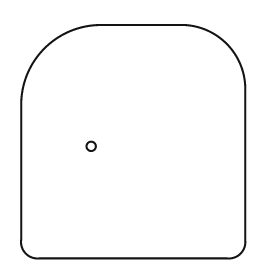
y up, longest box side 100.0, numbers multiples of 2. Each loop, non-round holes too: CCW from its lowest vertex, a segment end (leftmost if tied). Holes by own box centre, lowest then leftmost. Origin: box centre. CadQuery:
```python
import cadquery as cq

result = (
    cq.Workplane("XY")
    .moveTo(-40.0, -50.0)
    .lineTo(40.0, -50.0)
    .threePointArc((46.0, -48.0), (48.0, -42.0))
    .lineTo(48.0, 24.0)
    .threePointArc((40.0, 42.0), (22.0, 50.0))
    .lineTo(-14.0, 50.0)
    .threePointArc((-38.0, 40.0), (-48.0, 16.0))
    .lineTo(-48.0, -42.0)
    .threePointArc((-46.0, -48.0), (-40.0, -50.0))
    .close()
    .moveTo(-18.0, -2.0)
    .circle(2.0)
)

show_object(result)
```